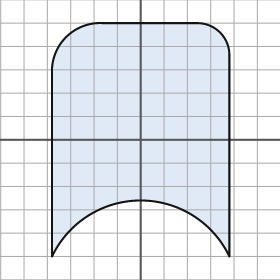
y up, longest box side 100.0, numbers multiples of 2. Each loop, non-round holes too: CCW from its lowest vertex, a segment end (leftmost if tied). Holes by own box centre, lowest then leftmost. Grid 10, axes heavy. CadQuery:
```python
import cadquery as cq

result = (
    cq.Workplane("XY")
    .moveTo(-38.0, -50.0)
    .threePointArc((0.0, -26.0), (38.0, -50.0))
    .lineTo(38.0, 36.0)
    .threePointArc((34.0, 46.0), (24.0, 50.0))
    .lineTo(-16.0, 50.0)
    .threePointArc((-32.0, 44.0), (-38.0, 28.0))
    .close()
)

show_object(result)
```